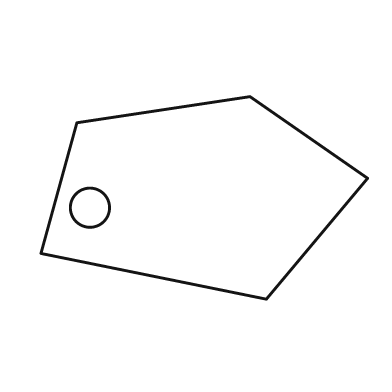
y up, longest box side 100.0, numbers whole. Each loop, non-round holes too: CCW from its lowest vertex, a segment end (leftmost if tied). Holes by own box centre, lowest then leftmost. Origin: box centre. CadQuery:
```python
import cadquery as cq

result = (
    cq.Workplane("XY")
    .moveTo(19.0, -31.0)
    .lineTo(50.0, 6.0)
    .lineTo(14.0, 31.0)
    .lineTo(-39.0, 23.0)
    .lineTo(-50.0, -17.0)
    .close()
    .moveTo(-35.0, -3.0)
    .circle(6.0)
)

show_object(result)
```